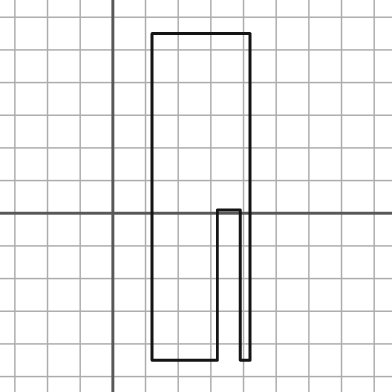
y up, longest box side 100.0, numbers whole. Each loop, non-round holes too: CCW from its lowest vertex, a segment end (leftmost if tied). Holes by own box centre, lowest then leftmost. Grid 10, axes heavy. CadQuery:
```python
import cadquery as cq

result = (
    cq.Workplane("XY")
    .moveTo(12.0, -45.0)
    .lineTo(32.0, -45.0)
    .lineTo(32.0, 1.0)
    .lineTo(39.0, 1.0)
    .lineTo(39.0, -45.0)
    .lineTo(42.0, -45.0)
    .lineTo(42.0, 55.0)
    .lineTo(12.0, 55.0)
    .close()
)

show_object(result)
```